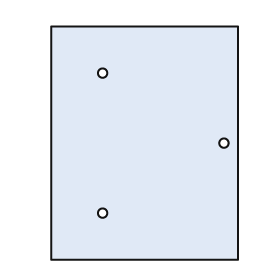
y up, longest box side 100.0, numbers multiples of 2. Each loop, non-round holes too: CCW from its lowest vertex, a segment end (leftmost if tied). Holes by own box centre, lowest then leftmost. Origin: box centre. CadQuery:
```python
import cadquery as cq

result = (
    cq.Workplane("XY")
    .moveTo(-40.0, -50.0)
    .lineTo(40.0, -50.0)
    .lineTo(40.0, 50.0)
    .lineTo(-40.0, 50.0)
    .close()
    .moveTo(-18.0, -30.0)
    .circle(2.0)
    .moveTo(34.0, 0.0)
    .circle(2.0)
    .moveTo(-18.0, 30.0)
    .circle(2.0)
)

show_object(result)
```